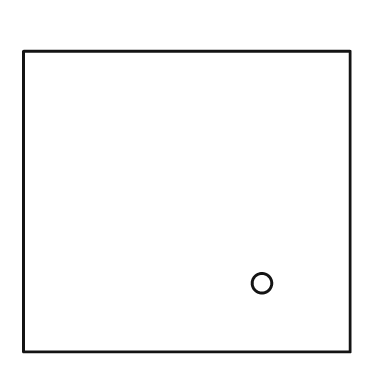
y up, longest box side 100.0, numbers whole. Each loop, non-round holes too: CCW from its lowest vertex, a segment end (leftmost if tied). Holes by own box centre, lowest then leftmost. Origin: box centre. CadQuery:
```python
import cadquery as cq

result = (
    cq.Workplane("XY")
    .moveTo(-50.0, -46.0)
    .lineTo(50.0, -46.0)
    .lineTo(50.0, 46.0)
    .lineTo(-50.0, 46.0)
    .close()
    .moveTo(23.0, -25.0)
    .circle(3.0)
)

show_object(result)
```